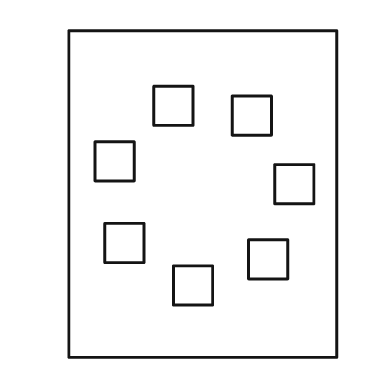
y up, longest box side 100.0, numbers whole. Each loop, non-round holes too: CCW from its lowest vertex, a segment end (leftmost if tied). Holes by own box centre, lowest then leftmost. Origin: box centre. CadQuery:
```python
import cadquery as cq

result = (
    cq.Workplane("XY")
    .moveTo(-41.0, -50.0)
    .lineTo(41.0, -50.0)
    .lineTo(41.0, 50.0)
    .lineTo(-41.0, 50.0)
    .close()
    .moveTo(-9.0, -34.0)
    .lineTo(3.0, -34.0)
    .lineTo(3.0, -22.0)
    .lineTo(-9.0, -22.0)
    .close()
    .moveTo(14.0, -26.0)
    .lineTo(26.0, -26.0)
    .lineTo(26.0, -14.0)
    .lineTo(14.0, -14.0)
    .close()
    .moveTo(-30.0, -21.0)
    .lineTo(-18.0, -21.0)
    .lineTo(-18.0, -9.0)
    .lineTo(-30.0, -9.0)
    .close()
    .moveTo(22.0, -3.0)
    .lineTo(34.0, -3.0)
    .lineTo(34.0, 9.0)
    .lineTo(22.0, 9.0)
    .close()
    .moveTo(-33.0, 4.0)
    .lineTo(-21.0, 4.0)
    .lineTo(-21.0, 16.0)
    .lineTo(-33.0, 16.0)
    .close()
    .moveTo(9.0, 18.0)
    .lineTo(21.0, 18.0)
    .lineTo(21.0, 30.0)
    .lineTo(9.0, 30.0)
    .close()
    .moveTo(-15.0, 21.0)
    .lineTo(-3.0, 21.0)
    .lineTo(-3.0, 33.0)
    .lineTo(-15.0, 33.0)
    .close()
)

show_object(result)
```